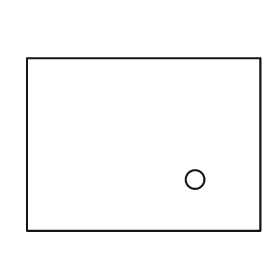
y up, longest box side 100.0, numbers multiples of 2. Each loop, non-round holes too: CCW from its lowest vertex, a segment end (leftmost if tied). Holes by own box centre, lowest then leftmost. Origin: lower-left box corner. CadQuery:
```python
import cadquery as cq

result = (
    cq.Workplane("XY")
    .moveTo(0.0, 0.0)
    .lineTo(100.0, 0.0)
    .lineTo(100.0, 74.0)
    .lineTo(0.0, 74.0)
    .close()
    .moveTo(72.0, 22.0)
    .circle(4.0)
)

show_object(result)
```